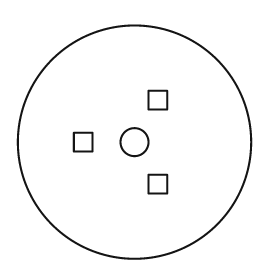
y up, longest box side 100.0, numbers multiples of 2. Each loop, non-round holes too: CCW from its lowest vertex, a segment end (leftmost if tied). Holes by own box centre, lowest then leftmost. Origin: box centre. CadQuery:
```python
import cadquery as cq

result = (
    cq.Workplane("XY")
    .moveTo(0.0, 0.0)
    .circle(50.0)
    .moveTo(6.0, -22.0)
    .lineTo(14.0, -22.0)
    .lineTo(14.0, -14.0)
    .lineTo(6.0, -14.0)
    .close()
    .moveTo(-26.0, -4.0)
    .lineTo(-18.0, -4.0)
    .lineTo(-18.0, 4.0)
    .lineTo(-26.0, 4.0)
    .close()
    .moveTo(0.0, 0.0)
    .circle(6.0)
    .moveTo(6.0, 14.0)
    .lineTo(14.0, 14.0)
    .lineTo(14.0, 22.0)
    .lineTo(6.0, 22.0)
    .close()
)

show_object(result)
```